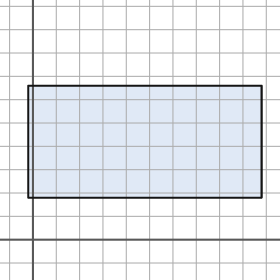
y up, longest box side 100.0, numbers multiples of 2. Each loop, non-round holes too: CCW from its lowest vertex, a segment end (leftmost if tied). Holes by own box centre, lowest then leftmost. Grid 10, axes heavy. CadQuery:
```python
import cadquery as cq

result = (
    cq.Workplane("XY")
    .moveTo(-2.0, 18.0)
    .lineTo(98.0, 18.0)
    .lineTo(98.0, 66.0)
    .lineTo(-2.0, 66.0)
    .close()
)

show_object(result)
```